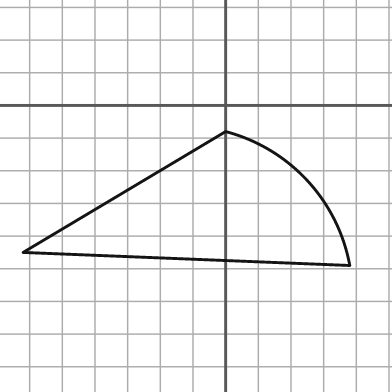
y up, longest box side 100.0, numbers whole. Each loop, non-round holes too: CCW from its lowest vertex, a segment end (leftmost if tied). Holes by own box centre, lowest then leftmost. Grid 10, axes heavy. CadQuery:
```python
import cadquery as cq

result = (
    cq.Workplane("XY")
    .moveTo(38.0, -49.0)
    .threePointArc((25.0, -23.0), (0.0, -8.0))
    .lineTo(-62.0, -45.0)
    .close()
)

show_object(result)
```